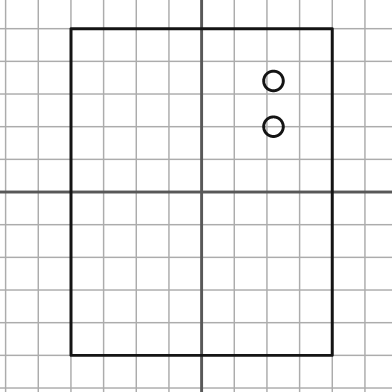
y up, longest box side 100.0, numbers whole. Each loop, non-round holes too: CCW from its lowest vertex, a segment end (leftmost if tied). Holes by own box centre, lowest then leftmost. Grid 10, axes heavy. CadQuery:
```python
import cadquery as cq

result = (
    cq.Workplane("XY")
    .moveTo(-40.0, -50.0)
    .lineTo(40.0, -50.0)
    .lineTo(40.0, 50.0)
    .lineTo(-40.0, 50.0)
    .close()
    .moveTo(22.0, 20.0)
    .circle(3.0)
    .moveTo(22.0, 34.0)
    .circle(3.0)
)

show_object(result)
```